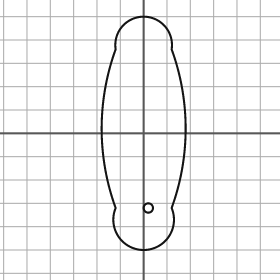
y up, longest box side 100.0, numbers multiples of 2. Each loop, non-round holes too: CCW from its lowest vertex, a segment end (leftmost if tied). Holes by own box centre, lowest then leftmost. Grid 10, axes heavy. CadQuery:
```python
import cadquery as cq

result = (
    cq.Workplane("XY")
    .moveTo(-12.0, -32.0)
    .threePointArc((0.0, -50.0), (12.0, -32.0))
    .threePointArc((18.0, 2.0), (12.0, 36.0))
    .threePointArc((0.0, 50.0), (-12.0, 36.0))
    .threePointArc((-18.0, 2.0), (-12.0, -32.0))
    .close()
    .moveTo(2.0, -32.0)
    .circle(2.0)
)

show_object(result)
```